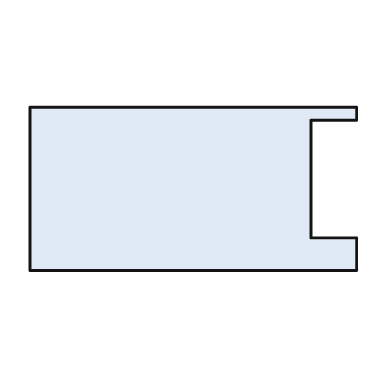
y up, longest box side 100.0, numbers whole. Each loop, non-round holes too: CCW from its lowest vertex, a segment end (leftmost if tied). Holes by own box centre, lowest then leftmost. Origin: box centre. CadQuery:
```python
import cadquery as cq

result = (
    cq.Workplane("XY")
    .moveTo(-50.0, -25.0)
    .lineTo(50.0, -25.0)
    .lineTo(50.0, -15.0)
    .lineTo(36.0, -15.0)
    .lineTo(36.0, 21.0)
    .lineTo(50.0, 21.0)
    .lineTo(50.0, 25.0)
    .lineTo(-50.0, 25.0)
    .close()
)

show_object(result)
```